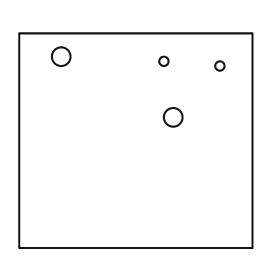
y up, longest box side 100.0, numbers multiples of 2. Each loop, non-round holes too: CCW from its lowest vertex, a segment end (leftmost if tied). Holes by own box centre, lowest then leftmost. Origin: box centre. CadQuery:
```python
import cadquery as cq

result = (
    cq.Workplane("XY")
    .moveTo(-50.0, -46.0)
    .lineTo(50.0, -46.0)
    .lineTo(50.0, 46.0)
    .lineTo(-50.0, 46.0)
    .close()
    .moveTo(16.0, 10.0)
    .circle(4.0)
    .moveTo(36.0, 32.0)
    .circle(2.0)
    .moveTo(12.0, 34.0)
    .circle(2.0)
    .moveTo(-32.0, 36.0)
    .circle(4.0)
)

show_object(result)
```